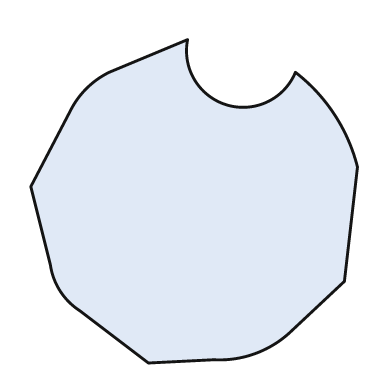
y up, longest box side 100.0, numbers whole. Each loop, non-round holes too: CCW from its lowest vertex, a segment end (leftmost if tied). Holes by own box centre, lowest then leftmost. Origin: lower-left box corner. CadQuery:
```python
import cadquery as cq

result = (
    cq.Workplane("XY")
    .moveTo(36.0, 0.0)
    .lineTo(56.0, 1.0)
    .threePointArc((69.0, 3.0), (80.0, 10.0))
    .lineTo(96.0, 25.0)
    .lineTo(100.0, 60.0)
    .threePointArc((93.0, 76.0), (81.0, 89.0))
    .threePointArc((60.0, 79.0), (48.0, 99.0))
    .lineTo(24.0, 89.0)
    .threePointArc((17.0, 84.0), (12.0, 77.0))
    .lineTo(0.0, 54.0)
    .lineTo(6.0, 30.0)
    .threePointArc((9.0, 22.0), (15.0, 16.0))
    .close()
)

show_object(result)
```